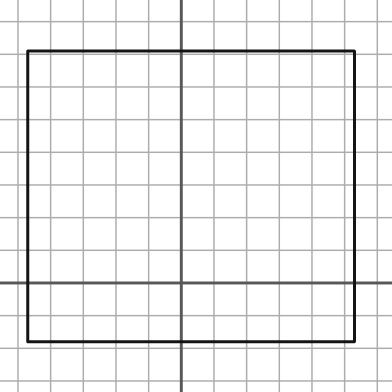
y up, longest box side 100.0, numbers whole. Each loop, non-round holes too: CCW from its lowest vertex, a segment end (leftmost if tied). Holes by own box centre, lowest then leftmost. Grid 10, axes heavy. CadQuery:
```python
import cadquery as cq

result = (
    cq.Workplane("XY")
    .moveTo(-47.0, -18.0)
    .lineTo(53.0, -18.0)
    .lineTo(53.0, 71.0)
    .lineTo(-47.0, 71.0)
    .close()
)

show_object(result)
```